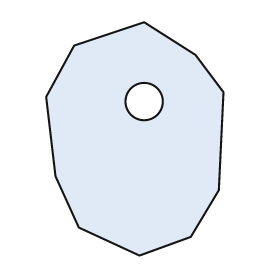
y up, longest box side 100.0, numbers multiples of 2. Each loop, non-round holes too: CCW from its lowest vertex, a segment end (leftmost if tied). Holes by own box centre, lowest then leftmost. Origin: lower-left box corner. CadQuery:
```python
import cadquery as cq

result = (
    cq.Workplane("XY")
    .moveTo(40.0, 0.0)
    .lineTo(62.0, 8.0)
    .lineTo(74.0, 28.0)
    .lineTo(76.0, 70.0)
    .lineTo(64.0, 86.0)
    .lineTo(42.0, 100.0)
    .lineTo(12.0, 90.0)
    .lineTo(0.0, 68.0)
    .lineTo(4.0, 34.0)
    .lineTo(14.0, 12.0)
    .close()
    .moveTo(42.0, 66.0)
    .circle(8.0)
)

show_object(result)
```